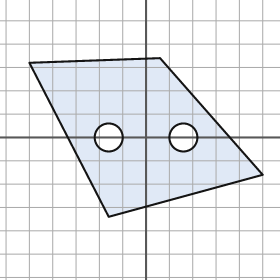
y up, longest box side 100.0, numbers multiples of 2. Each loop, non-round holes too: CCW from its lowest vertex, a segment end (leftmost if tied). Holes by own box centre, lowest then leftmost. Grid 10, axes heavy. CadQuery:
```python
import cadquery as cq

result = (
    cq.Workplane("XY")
    .moveTo(-16.0, -34.0)
    .lineTo(50.0, -16.0)
    .lineTo(6.0, 34.0)
    .lineTo(-50.0, 32.0)
    .close()
    .moveTo(-16.0, 0.0)
    .circle(6.0)
    .moveTo(16.0, 0.0)
    .circle(6.0)
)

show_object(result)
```